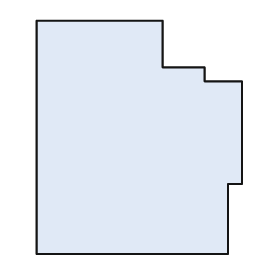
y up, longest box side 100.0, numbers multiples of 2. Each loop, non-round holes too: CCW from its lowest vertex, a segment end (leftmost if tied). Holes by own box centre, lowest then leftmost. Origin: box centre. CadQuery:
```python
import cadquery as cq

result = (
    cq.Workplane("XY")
    .moveTo(-44.0, -50.0)
    .lineTo(38.0, -50.0)
    .lineTo(38.0, -20.0)
    .lineTo(44.0, -20.0)
    .lineTo(44.0, 24.0)
    .lineTo(28.0, 24.0)
    .lineTo(28.0, 30.0)
    .lineTo(10.0, 30.0)
    .lineTo(10.0, 50.0)
    .lineTo(-44.0, 50.0)
    .close()
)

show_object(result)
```